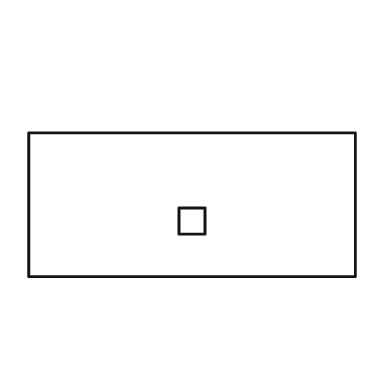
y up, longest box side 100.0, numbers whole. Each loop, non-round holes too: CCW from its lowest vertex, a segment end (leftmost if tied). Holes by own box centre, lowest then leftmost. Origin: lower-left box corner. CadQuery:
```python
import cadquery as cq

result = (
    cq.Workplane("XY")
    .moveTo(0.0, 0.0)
    .lineTo(100.0, 0.0)
    .lineTo(100.0, 44.0)
    .lineTo(0.0, 44.0)
    .close()
    .moveTo(46.0, 13.0)
    .lineTo(54.0, 13.0)
    .lineTo(54.0, 21.0)
    .lineTo(46.0, 21.0)
    .close()
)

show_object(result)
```